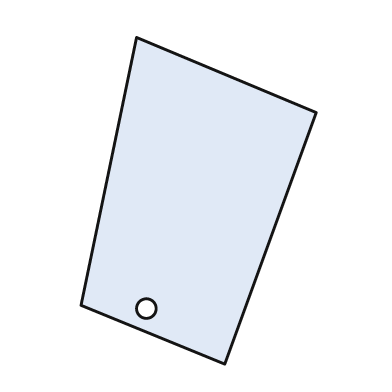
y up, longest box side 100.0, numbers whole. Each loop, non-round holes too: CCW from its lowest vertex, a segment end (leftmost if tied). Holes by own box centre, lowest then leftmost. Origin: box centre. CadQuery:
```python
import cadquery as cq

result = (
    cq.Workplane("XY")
    .moveTo(8.0, -50.0)
    .lineTo(36.0, 27.0)
    .lineTo(-19.0, 50.0)
    .lineTo(-36.0, -32.0)
    .close()
    .moveTo(-16.0, -33.0)
    .circle(3.0)
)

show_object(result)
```